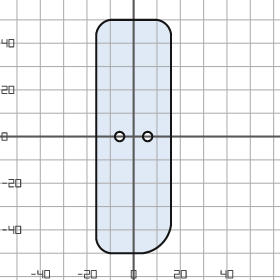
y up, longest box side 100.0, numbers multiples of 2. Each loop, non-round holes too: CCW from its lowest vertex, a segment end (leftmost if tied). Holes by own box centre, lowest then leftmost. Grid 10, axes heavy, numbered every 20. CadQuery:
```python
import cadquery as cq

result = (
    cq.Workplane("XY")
    .moveTo(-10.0, -50.0)
    .lineTo(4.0, -50.0)
    .threePointArc((12.0, -46.0), (16.0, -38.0))
    .lineTo(16.0, 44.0)
    .threePointArc((14.0, 48.0), (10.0, 50.0))
    .lineTo(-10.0, 50.0)
    .threePointArc((-14.0, 48.0), (-16.0, 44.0))
    .lineTo(-16.0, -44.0)
    .threePointArc((-14.0, -48.0), (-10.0, -50.0))
    .close()
    .moveTo(-6.0, 0.0)
    .circle(2.0)
    .moveTo(6.0, 0.0)
    .circle(2.0)
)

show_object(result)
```